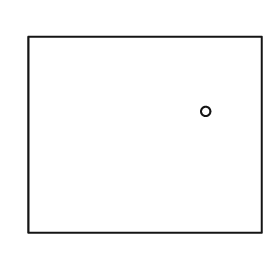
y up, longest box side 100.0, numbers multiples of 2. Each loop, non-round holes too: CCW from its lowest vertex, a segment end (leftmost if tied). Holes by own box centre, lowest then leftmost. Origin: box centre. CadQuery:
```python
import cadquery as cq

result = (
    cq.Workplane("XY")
    .moveTo(-50.0, -42.0)
    .lineTo(50.0, -42.0)
    .lineTo(50.0, 42.0)
    .lineTo(-50.0, 42.0)
    .close()
    .moveTo(26.0, 10.0)
    .circle(2.0)
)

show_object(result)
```